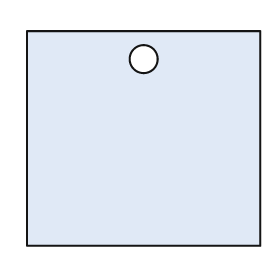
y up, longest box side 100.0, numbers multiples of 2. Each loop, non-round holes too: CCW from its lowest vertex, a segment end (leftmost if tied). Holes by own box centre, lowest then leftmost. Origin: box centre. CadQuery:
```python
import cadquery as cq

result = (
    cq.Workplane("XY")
    .moveTo(-50.0, -46.0)
    .lineTo(50.0, -46.0)
    .lineTo(50.0, 46.0)
    .lineTo(-50.0, 46.0)
    .close()
    .moveTo(0.0, 34.0)
    .circle(6.0)
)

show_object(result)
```